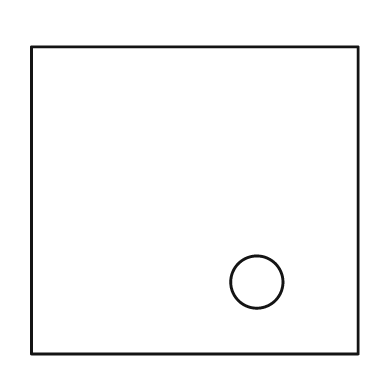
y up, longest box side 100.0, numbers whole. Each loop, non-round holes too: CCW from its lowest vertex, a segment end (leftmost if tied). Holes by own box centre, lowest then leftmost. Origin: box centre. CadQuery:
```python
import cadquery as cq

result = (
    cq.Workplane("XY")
    .moveTo(-50.0, -47.0)
    .lineTo(50.0, -47.0)
    .lineTo(50.0, 47.0)
    .lineTo(-50.0, 47.0)
    .close()
    .moveTo(19.0, -25.0)
    .circle(8.0)
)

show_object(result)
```